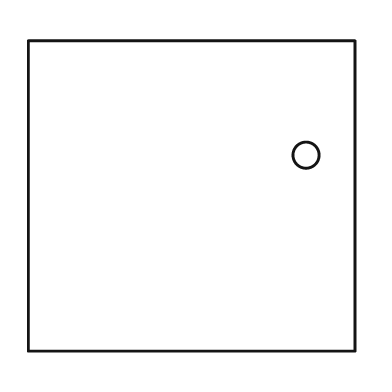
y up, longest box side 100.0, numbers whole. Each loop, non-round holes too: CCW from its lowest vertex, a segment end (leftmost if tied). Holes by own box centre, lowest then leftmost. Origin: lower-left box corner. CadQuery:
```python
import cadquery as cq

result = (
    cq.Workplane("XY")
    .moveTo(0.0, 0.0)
    .lineTo(100.0, 0.0)
    .lineTo(100.0, 95.0)
    .lineTo(0.0, 95.0)
    .close()
    .moveTo(85.0, 60.0)
    .circle(4.0)
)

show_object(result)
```